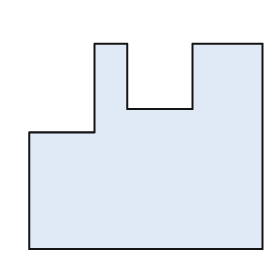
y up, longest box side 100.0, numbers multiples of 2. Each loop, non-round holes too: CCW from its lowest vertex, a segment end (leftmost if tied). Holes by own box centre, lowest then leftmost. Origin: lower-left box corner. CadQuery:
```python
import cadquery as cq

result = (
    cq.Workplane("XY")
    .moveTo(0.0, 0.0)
    .lineTo(100.0, 0.0)
    .lineTo(100.0, 88.0)
    .lineTo(70.0, 88.0)
    .lineTo(70.0, 60.0)
    .lineTo(42.0, 60.0)
    .lineTo(42.0, 88.0)
    .lineTo(28.0, 88.0)
    .lineTo(28.0, 50.0)
    .lineTo(0.0, 50.0)
    .close()
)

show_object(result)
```